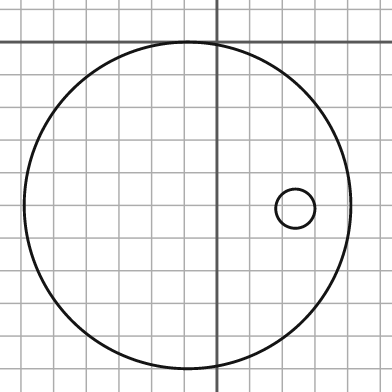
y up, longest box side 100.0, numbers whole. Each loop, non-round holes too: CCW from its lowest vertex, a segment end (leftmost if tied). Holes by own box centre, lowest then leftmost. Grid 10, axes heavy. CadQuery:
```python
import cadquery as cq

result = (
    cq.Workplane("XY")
    .moveTo(-9.0, -50.0)
    .circle(50.0)
    .moveTo(24.0, -51.0)
    .circle(6.0)
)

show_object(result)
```